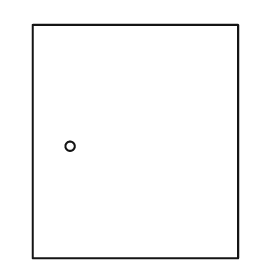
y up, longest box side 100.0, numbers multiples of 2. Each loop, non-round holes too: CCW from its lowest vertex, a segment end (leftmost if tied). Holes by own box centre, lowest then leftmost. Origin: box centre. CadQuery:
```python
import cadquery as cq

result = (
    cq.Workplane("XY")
    .moveTo(-44.0, -50.0)
    .lineTo(44.0, -50.0)
    .lineTo(44.0, 50.0)
    .lineTo(-44.0, 50.0)
    .close()
    .moveTo(-28.0, -2.0)
    .circle(2.0)
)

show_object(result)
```